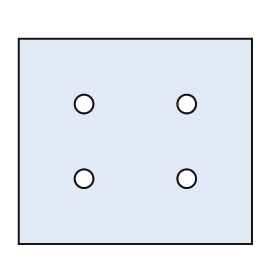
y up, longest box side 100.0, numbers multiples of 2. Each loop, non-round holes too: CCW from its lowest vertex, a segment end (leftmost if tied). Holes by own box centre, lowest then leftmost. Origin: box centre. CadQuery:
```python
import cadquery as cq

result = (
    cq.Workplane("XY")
    .moveTo(-50.0, -44.0)
    .lineTo(50.0, -44.0)
    .lineTo(50.0, 44.0)
    .lineTo(-50.0, 44.0)
    .close()
    .moveTo(-22.0, -16.0)
    .circle(4.0)
    .moveTo(22.0, -16.0)
    .circle(4.0)
    .moveTo(-22.0, 16.0)
    .circle(4.0)
    .moveTo(22.0, 16.0)
    .circle(4.0)
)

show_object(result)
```